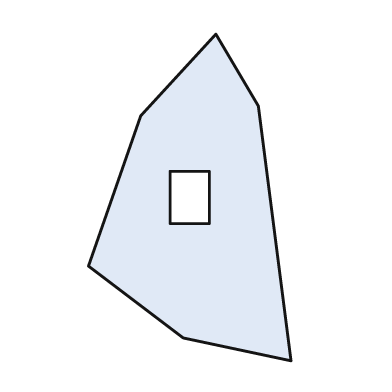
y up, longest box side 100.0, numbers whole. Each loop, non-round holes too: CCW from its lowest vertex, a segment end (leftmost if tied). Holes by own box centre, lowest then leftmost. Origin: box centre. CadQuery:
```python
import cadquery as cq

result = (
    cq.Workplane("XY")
    .moveTo(31.0, -50.0)
    .lineTo(21.0, 28.0)
    .lineTo(8.0, 50.0)
    .lineTo(-15.0, 25.0)
    .lineTo(-31.0, -21.0)
    .lineTo(-2.0, -43.0)
    .close()
    .moveTo(-6.0, -8.0)
    .lineTo(6.0, -8.0)
    .lineTo(6.0, 8.0)
    .lineTo(-6.0, 8.0)
    .close()
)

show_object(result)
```